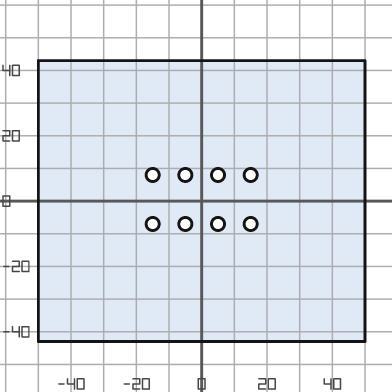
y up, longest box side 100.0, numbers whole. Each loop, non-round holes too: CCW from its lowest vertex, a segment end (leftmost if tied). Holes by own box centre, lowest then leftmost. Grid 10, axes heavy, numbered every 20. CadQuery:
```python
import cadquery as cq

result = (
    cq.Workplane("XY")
    .moveTo(-50.0, -43.0)
    .lineTo(50.0, -43.0)
    .lineTo(50.0, 43.0)
    .lineTo(-50.0, 43.0)
    .close()
    .moveTo(-15.0, -7.0)
    .circle(2.0)
    .moveTo(-5.0, -7.0)
    .circle(2.0)
    .moveTo(5.0, -7.0)
    .circle(2.0)
    .moveTo(15.0, -7.0)
    .circle(2.0)
    .moveTo(-15.0, 8.0)
    .circle(2.0)
    .moveTo(-5.0, 8.0)
    .circle(2.0)
    .moveTo(5.0, 8.0)
    .circle(2.0)
    .moveTo(15.0, 8.0)
    .circle(2.0)
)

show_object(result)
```